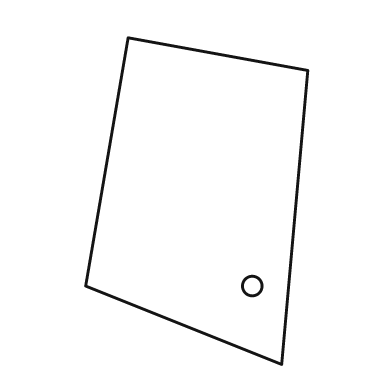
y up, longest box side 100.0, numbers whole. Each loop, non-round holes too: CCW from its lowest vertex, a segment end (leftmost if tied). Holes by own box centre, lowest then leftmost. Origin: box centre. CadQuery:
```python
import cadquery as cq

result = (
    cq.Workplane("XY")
    .moveTo(26.0, -50.0)
    .lineTo(34.0, 40.0)
    .lineTo(-21.0, 50.0)
    .lineTo(-34.0, -26.0)
    .close()
    .moveTo(17.0, -26.0)
    .circle(3.0)
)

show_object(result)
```